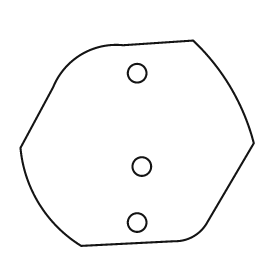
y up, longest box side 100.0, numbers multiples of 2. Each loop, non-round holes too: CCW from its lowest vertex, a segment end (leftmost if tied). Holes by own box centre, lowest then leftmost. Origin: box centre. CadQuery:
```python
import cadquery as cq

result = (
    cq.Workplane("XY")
    .moveTo(-24.0, -44.0)
    .lineTo(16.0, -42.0)
    .threePointArc((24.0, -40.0), (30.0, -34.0))
    .lineTo(50.0, 0.0)
    .threePointArc((40.0, 24.0), (24.0, 44.0))
    .lineTo(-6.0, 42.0)
    .threePointArc((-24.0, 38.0), (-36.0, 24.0))
    .lineTo(-50.0, -2.0)
    .threePointArc((-42.0, -26.0), (-24.0, -44.0))
    .close()
    .moveTo(0.0, -34.0)
    .circle(4.0)
    .moveTo(2.0, -10.0)
    .circle(4.0)
    .moveTo(0.0, 30.0)
    .circle(4.0)
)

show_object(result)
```